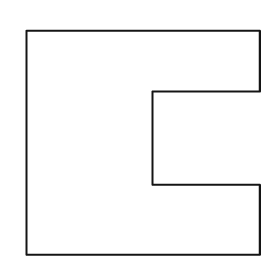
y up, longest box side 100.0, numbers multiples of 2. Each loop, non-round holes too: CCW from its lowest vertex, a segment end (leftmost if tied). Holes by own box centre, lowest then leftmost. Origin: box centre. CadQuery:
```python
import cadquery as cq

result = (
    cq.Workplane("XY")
    .moveTo(-50.0, -48.0)
    .lineTo(50.0, -48.0)
    .lineTo(50.0, -18.0)
    .lineTo(4.0, -18.0)
    .lineTo(4.0, 22.0)
    .lineTo(50.0, 22.0)
    .lineTo(50.0, 48.0)
    .lineTo(-50.0, 48.0)
    .close()
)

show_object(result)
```